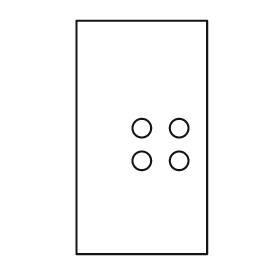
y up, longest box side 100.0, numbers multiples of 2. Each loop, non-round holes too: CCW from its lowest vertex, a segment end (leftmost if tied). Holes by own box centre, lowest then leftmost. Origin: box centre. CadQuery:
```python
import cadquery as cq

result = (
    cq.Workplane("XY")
    .moveTo(-28.0, -50.0)
    .lineTo(28.0, -50.0)
    .lineTo(28.0, 50.0)
    .lineTo(-28.0, 50.0)
    .close()
    .moveTo(0.0, -10.0)
    .circle(4.0)
    .moveTo(16.0, -10.0)
    .circle(4.0)
    .moveTo(0.0, 4.0)
    .circle(4.0)
    .moveTo(16.0, 4.0)
    .circle(4.0)
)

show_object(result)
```